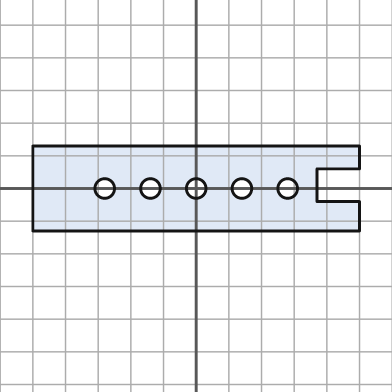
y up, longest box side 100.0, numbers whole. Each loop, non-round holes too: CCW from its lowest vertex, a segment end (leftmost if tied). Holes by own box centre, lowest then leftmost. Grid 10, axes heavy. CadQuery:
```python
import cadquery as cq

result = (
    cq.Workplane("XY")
    .moveTo(-50.0, -13.0)
    .lineTo(50.0, -13.0)
    .lineTo(50.0, -4.0)
    .lineTo(37.0, -4.0)
    .lineTo(37.0, 6.0)
    .lineTo(50.0, 6.0)
    .lineTo(50.0, 13.0)
    .lineTo(-50.0, 13.0)
    .close()
    .moveTo(-28.0, 0.0)
    .circle(3.0)
    .moveTo(-14.0, 0.0)
    .circle(3.0)
    .moveTo(0.0, 0.0)
    .circle(3.0)
    .moveTo(14.0, 0.0)
    .circle(3.0)
    .moveTo(28.0, 0.0)
    .circle(3.0)
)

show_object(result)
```